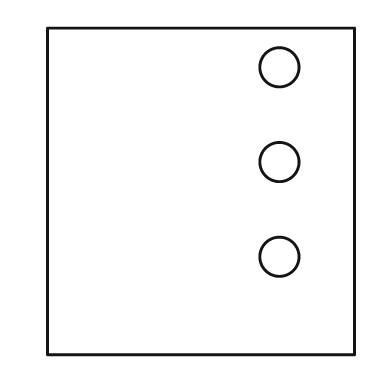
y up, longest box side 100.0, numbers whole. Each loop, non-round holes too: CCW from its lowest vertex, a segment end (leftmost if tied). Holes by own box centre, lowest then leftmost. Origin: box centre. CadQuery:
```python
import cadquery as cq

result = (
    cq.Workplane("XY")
    .moveTo(-47.0, -50.0)
    .lineTo(47.0, -50.0)
    .lineTo(47.0, 50.0)
    .lineTo(-47.0, 50.0)
    .close()
    .moveTo(24.0, -20.0)
    .circle(6.0)
    .moveTo(24.0, 9.0)
    .circle(6.0)
    .moveTo(24.0, 38.0)
    .circle(6.0)
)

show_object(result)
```